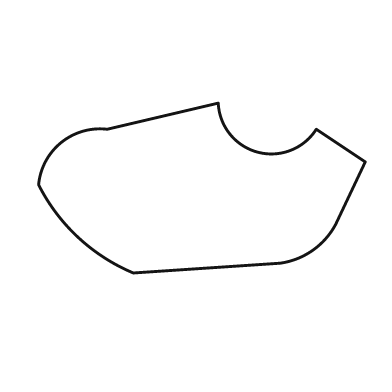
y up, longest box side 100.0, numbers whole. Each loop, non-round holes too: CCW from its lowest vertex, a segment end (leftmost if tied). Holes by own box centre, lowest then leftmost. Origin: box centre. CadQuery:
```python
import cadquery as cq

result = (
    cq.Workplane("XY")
    .moveTo(-21.0, -26.0)
    .lineTo(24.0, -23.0)
    .threePointArc((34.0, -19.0), (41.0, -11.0))
    .lineTo(50.0, 8.0)
    .lineTo(35.0, 18.0)
    .threePointArc((17.0, 11.0), (5.0, 26.0))
    .lineTo(-29.0, 18.0)
    .threePointArc((-43.0, 14.0), (-50.0, 1.0))
    .threePointArc((-38.0, -15.0), (-21.0, -26.0))
    .close()
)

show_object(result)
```